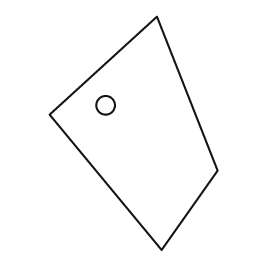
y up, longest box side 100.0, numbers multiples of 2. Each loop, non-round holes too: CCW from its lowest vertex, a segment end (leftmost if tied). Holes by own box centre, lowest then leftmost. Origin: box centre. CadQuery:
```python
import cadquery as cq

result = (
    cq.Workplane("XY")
    .moveTo(12.0, -50.0)
    .lineTo(36.0, -16.0)
    .lineTo(10.0, 50.0)
    .lineTo(-36.0, 8.0)
    .close()
    .moveTo(-12.0, 12.0)
    .circle(4.0)
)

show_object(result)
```